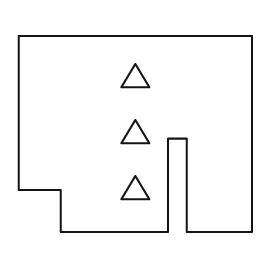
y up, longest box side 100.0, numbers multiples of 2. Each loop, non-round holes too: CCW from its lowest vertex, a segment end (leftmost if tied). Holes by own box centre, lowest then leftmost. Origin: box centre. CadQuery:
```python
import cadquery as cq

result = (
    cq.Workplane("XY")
    .moveTo(-32.0, -42.0)
    .lineTo(14.0, -42.0)
    .lineTo(14.0, -2.0)
    .lineTo(22.0, -2.0)
    .lineTo(22.0, -42.0)
    .lineTo(50.0, -42.0)
    .lineTo(50.0, 42.0)
    .lineTo(-50.0, 42.0)
    .lineTo(-50.0, -24.0)
    .lineTo(-32.0, -24.0)
    .close()
    .moveTo(-6.0, -28.0)
    .lineTo(6.0, -28.0)
    .lineTo(0.0, -18.0)
    .close()
    .moveTo(-6.0, -4.0)
    .lineTo(6.0, -4.0)
    .lineTo(0.0, 6.0)
    .close()
    .moveTo(-6.0, 20.0)
    .lineTo(6.0, 20.0)
    .lineTo(0.0, 30.0)
    .close()
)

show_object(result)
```